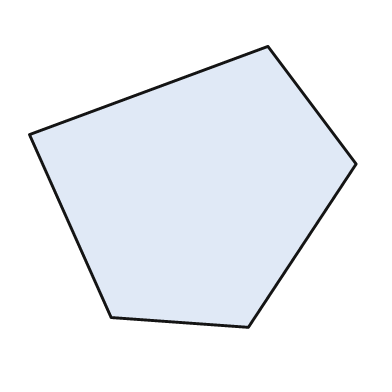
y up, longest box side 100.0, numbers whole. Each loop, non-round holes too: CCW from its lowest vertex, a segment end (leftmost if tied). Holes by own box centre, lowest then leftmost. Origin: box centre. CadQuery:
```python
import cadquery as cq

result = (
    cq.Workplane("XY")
    .moveTo(17.0, -43.0)
    .lineTo(50.0, 7.0)
    .lineTo(23.0, 43.0)
    .lineTo(-50.0, 16.0)
    .lineTo(-25.0, -40.0)
    .close()
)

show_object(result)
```